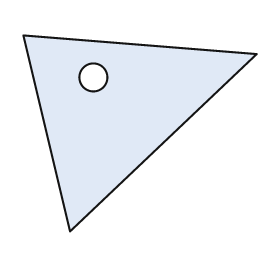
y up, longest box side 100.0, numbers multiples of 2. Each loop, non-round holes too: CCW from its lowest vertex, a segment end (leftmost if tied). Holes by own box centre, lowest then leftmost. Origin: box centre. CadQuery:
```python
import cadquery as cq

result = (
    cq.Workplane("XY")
    .moveTo(-30.0, -42.0)
    .lineTo(50.0, 34.0)
    .lineTo(-50.0, 42.0)
    .close()
    .moveTo(-20.0, 24.0)
    .circle(6.0)
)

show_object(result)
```